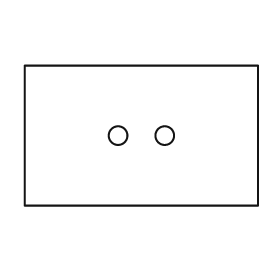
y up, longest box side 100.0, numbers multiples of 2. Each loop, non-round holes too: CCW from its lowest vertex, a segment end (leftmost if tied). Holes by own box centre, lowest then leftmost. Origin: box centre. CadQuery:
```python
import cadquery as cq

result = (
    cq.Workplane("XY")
    .moveTo(-50.0, -30.0)
    .lineTo(50.0, -30.0)
    .lineTo(50.0, 30.0)
    .lineTo(-50.0, 30.0)
    .close()
    .moveTo(-10.0, 0.0)
    .circle(4.0)
    .moveTo(10.0, 0.0)
    .circle(4.0)
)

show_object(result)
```